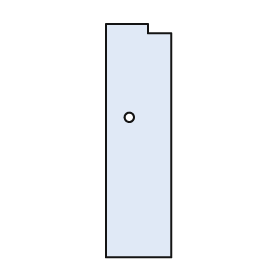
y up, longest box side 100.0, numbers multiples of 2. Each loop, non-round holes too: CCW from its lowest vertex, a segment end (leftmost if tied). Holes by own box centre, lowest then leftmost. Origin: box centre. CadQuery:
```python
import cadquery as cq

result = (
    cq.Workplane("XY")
    .moveTo(-14.0, -50.0)
    .lineTo(14.0, -50.0)
    .lineTo(14.0, 46.0)
    .lineTo(4.0, 46.0)
    .lineTo(4.0, 50.0)
    .lineTo(-14.0, 50.0)
    .close()
    .moveTo(-4.0, 10.0)
    .circle(2.0)
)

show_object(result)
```